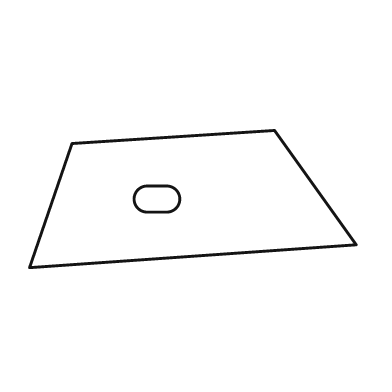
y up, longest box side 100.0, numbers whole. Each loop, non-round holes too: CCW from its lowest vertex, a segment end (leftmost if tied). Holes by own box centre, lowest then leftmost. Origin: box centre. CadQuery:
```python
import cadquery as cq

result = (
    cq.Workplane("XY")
    .moveTo(-50.0, -21.0)
    .lineTo(50.0, -14.0)
    .lineTo(25.0, 21.0)
    .lineTo(-37.0, 17.0)
    .close()
    .moveTo(-14.0, -4.0)
    .lineTo(-8.0, -4.0)
    .threePointArc((-4.0, 0.0), (-8.0, 4.0))
    .lineTo(-14.0, 4.0)
    .threePointArc((-18.0, 0.0), (-14.0, -4.0))
    .close()
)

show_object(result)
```